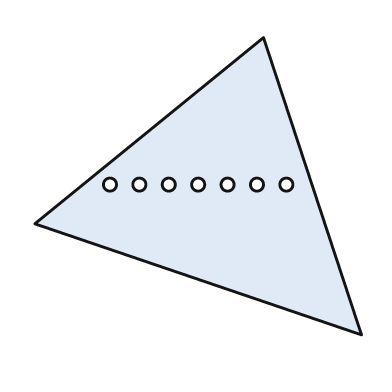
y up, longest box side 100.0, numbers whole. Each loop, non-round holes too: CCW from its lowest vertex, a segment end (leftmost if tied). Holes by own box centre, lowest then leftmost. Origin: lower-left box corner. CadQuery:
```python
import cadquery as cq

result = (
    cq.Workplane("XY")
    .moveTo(100.0, 0.0)
    .lineTo(70.0, 91.0)
    .lineTo(0.0, 34.0)
    .close()
    .moveTo(23.0, 46.0)
    .circle(2.0)
    .moveTo(32.0, 46.0)
    .circle(2.0)
    .moveTo(41.0, 46.0)
    .circle(2.0)
    .moveTo(50.0, 46.0)
    .circle(2.0)
    .moveTo(59.0, 46.0)
    .circle(2.0)
    .moveTo(68.0, 46.0)
    .circle(2.0)
    .moveTo(77.0, 46.0)
    .circle(2.0)
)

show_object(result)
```